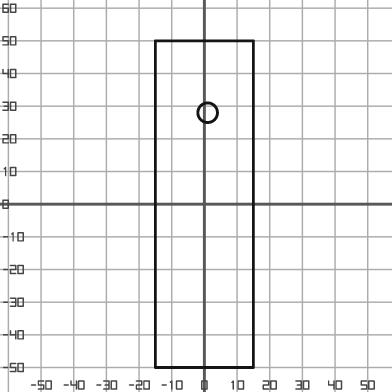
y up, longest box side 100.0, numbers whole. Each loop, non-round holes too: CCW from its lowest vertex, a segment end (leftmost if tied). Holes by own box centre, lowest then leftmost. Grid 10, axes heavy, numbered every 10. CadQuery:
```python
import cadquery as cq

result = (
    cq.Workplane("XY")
    .moveTo(-15.0, -50.0)
    .lineTo(15.0, -50.0)
    .lineTo(15.0, 50.0)
    .lineTo(-15.0, 50.0)
    .close()
    .moveTo(1.0, 28.0)
    .circle(3.0)
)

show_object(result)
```